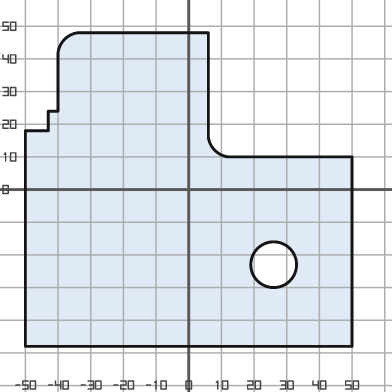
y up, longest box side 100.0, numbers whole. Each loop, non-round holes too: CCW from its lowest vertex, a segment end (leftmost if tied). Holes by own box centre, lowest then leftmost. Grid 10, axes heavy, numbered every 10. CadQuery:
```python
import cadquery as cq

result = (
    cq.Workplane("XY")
    .moveTo(-50.0, -48.0)
    .lineTo(50.0, -48.0)
    .lineTo(50.0, 10.0)
    .lineTo(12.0, 10.0)
    .threePointArc((8.0, 12.0), (6.0, 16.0))
    .lineTo(6.0, 48.0)
    .lineTo(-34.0, 48.0)
    .threePointArc((-38.0, 46.0), (-40.0, 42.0))
    .lineTo(-40.0, 24.0)
    .lineTo(-43.0, 24.0)
    .lineTo(-43.0, 18.0)
    .lineTo(-50.0, 18.0)
    .close()
    .moveTo(26.0, -23.0)
    .circle(7.0)
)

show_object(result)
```